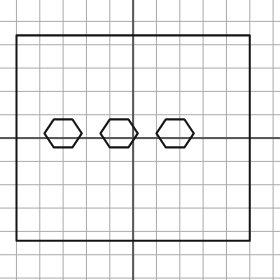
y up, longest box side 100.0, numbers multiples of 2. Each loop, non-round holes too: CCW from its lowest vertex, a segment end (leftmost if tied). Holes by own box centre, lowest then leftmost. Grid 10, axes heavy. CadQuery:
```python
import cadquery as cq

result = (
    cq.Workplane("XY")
    .moveTo(-50.0, -44.0)
    .lineTo(50.0, -44.0)
    .lineTo(50.0, 44.0)
    .lineTo(-50.0, 44.0)
    .close()
    .moveTo(-34.0, -4.0)
    .lineTo(-26.0, -4.0)
    .lineTo(-22.0, 2.0)
    .lineTo(-26.0, 8.0)
    .lineTo(-34.0, 8.0)
    .lineTo(-38.0, 2.0)
    .close()
    .moveTo(-10.0, -4.0)
    .lineTo(-2.0, -4.0)
    .lineTo(2.0, 2.0)
    .lineTo(-2.0, 8.0)
    .lineTo(-10.0, 8.0)
    .lineTo(-14.0, 2.0)
    .close()
    .moveTo(14.0, -4.0)
    .lineTo(22.0, -4.0)
    .lineTo(26.0, 2.0)
    .lineTo(22.0, 8.0)
    .lineTo(14.0, 8.0)
    .lineTo(10.0, 2.0)
    .close()
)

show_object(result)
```